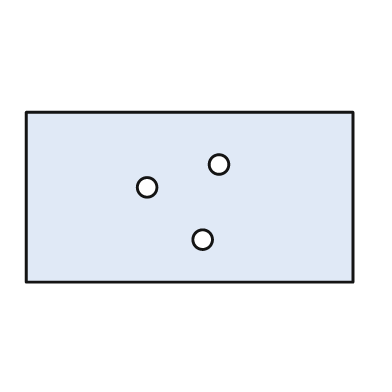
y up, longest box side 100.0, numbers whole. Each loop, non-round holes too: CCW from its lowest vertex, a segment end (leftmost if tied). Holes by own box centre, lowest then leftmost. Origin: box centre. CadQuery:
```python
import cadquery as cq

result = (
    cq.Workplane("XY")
    .moveTo(-50.0, -26.0)
    .lineTo(50.0, -26.0)
    .lineTo(50.0, 26.0)
    .lineTo(-50.0, 26.0)
    .close()
    .moveTo(4.0, -13.0)
    .circle(3.0)
    .moveTo(-13.0, 3.0)
    .circle(3.0)
    .moveTo(9.0, 10.0)
    .circle(3.0)
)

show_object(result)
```